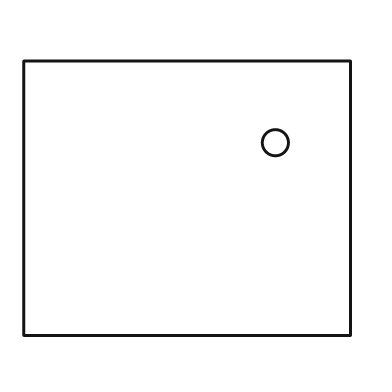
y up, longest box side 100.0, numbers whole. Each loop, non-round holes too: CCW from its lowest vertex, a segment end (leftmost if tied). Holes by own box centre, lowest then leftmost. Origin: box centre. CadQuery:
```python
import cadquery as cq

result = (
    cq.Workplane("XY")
    .moveTo(-50.0, -42.0)
    .lineTo(50.0, -42.0)
    .lineTo(50.0, 42.0)
    .lineTo(-50.0, 42.0)
    .close()
    .moveTo(27.0, 17.0)
    .circle(4.0)
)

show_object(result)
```